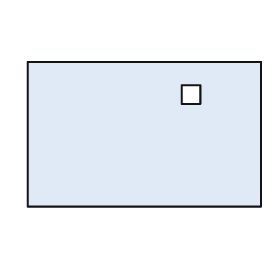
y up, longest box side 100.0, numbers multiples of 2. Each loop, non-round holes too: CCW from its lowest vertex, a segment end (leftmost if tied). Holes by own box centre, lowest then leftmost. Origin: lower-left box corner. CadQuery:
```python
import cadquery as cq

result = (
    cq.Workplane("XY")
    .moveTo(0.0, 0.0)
    .lineTo(100.0, 0.0)
    .lineTo(100.0, 62.0)
    .lineTo(0.0, 62.0)
    .close()
    .moveTo(66.0, 44.0)
    .lineTo(74.0, 44.0)
    .lineTo(74.0, 52.0)
    .lineTo(66.0, 52.0)
    .close()
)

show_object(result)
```